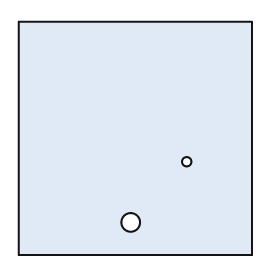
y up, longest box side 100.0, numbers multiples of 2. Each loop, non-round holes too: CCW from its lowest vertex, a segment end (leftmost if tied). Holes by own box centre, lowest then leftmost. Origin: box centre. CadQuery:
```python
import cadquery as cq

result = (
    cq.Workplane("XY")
    .moveTo(-50.0, -50.0)
    .lineTo(50.0, -50.0)
    .lineTo(50.0, 50.0)
    .lineTo(-50.0, 50.0)
    .close()
    .moveTo(-2.0, -36.0)
    .circle(4.0)
    .moveTo(22.0, -10.0)
    .circle(2.0)
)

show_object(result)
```